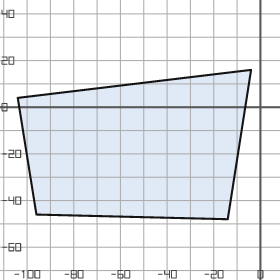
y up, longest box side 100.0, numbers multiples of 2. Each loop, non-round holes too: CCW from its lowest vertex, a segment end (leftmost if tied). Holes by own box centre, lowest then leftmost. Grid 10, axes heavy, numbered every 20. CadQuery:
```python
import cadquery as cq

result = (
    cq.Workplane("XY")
    .moveTo(-14.0, -48.0)
    .lineTo(-4.0, 16.0)
    .lineTo(-104.0, 4.0)
    .lineTo(-96.0, -46.0)
    .close()
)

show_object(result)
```